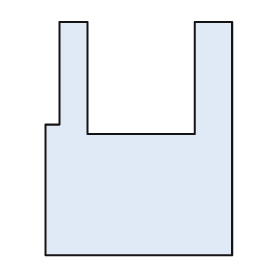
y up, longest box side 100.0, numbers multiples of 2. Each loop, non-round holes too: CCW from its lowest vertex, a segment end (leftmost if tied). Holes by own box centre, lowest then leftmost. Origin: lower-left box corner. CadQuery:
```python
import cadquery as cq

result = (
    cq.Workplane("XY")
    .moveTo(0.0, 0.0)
    .lineTo(80.0, 0.0)
    .lineTo(80.0, 100.0)
    .lineTo(64.0, 100.0)
    .lineTo(64.0, 52.0)
    .lineTo(18.0, 52.0)
    .lineTo(18.0, 100.0)
    .lineTo(6.0, 100.0)
    .lineTo(6.0, 56.0)
    .lineTo(0.0, 56.0)
    .close()
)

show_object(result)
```